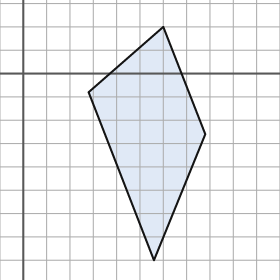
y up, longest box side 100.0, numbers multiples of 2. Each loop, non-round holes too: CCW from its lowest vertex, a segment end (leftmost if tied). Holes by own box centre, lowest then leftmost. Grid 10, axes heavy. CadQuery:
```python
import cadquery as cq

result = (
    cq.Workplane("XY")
    .moveTo(56.0, -80.0)
    .lineTo(78.0, -26.0)
    .lineTo(60.0, 20.0)
    .lineTo(28.0, -8.0)
    .close()
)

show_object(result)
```